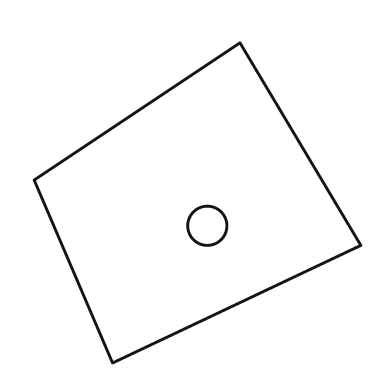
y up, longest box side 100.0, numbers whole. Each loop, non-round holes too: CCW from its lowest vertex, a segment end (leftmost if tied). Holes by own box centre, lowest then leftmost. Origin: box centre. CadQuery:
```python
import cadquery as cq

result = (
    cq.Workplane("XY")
    .moveTo(-26.0, -49.0)
    .lineTo(50.0, -13.0)
    .lineTo(13.0, 49.0)
    .lineTo(-50.0, 7.0)
    .close()
    .moveTo(3.0, -7.0)
    .circle(6.0)
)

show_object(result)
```